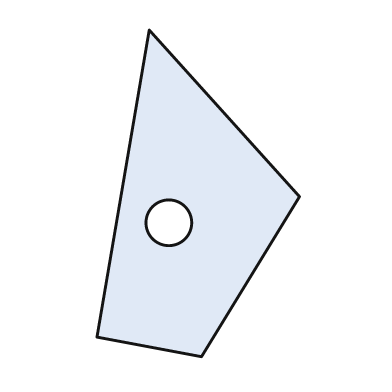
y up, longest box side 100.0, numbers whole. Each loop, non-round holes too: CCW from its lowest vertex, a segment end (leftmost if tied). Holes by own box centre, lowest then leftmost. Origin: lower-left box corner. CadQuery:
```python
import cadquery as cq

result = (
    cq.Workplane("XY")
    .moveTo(32.0, 0.0)
    .lineTo(62.0, 49.0)
    .lineTo(16.0, 100.0)
    .lineTo(0.0, 6.0)
    .close()
    .moveTo(22.0, 41.0)
    .circle(7.0)
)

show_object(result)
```